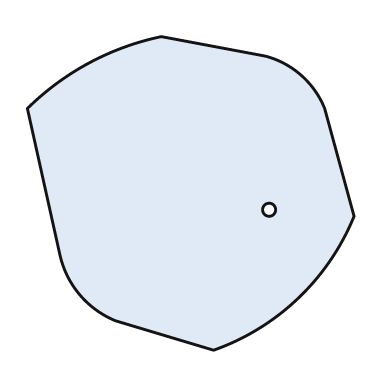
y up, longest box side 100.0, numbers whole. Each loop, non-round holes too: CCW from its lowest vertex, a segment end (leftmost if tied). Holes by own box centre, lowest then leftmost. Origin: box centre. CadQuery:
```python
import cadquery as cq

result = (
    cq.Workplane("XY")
    .moveTo(7.0, -48.0)
    .threePointArc((33.0, -32.0), (50.0, -7.0))
    .lineTo(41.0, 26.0)
    .threePointArc((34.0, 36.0), (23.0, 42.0))
    .lineTo(-9.0, 48.0)
    .threePointArc((-31.0, 40.0), (-50.0, 26.0))
    .lineTo(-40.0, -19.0)
    .threePointArc((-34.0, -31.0), (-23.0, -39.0))
    .close()
    .moveTo(24.0, -5.0)
    .circle(2.0)
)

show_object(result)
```